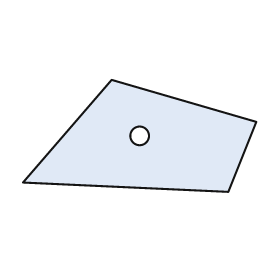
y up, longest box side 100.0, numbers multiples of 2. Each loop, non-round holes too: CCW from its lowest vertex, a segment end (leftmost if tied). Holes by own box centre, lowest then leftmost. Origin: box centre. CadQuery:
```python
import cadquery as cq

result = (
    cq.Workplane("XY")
    .moveTo(38.0, -24.0)
    .lineTo(50.0, 6.0)
    .lineTo(-12.0, 24.0)
    .lineTo(-50.0, -20.0)
    .close()
    .moveTo(0.0, 0.0)
    .circle(4.0)
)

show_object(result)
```